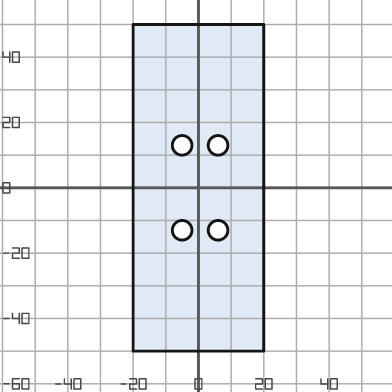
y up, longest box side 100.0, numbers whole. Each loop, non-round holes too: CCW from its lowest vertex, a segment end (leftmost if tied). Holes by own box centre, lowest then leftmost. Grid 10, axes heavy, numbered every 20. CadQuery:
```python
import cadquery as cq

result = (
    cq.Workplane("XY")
    .moveTo(-20.0, -50.0)
    .lineTo(20.0, -50.0)
    .lineTo(20.0, 50.0)
    .lineTo(-20.0, 50.0)
    .close()
    .moveTo(-5.0, -13.0)
    .circle(3.0)
    .moveTo(6.0, -13.0)
    .circle(3.0)
    .moveTo(-5.0, 13.0)
    .circle(3.0)
    .moveTo(6.0, 13.0)
    .circle(3.0)
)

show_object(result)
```